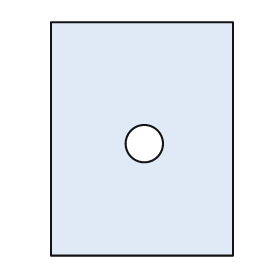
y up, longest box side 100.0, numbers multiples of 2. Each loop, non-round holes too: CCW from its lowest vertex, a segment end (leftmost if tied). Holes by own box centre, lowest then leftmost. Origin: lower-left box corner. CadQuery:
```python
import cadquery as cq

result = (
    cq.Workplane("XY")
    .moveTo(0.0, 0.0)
    .lineTo(78.0, 0.0)
    .lineTo(78.0, 100.0)
    .lineTo(0.0, 100.0)
    .close()
    .moveTo(40.0, 48.0)
    .circle(8.0)
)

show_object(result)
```